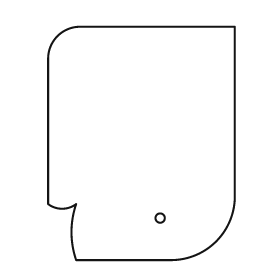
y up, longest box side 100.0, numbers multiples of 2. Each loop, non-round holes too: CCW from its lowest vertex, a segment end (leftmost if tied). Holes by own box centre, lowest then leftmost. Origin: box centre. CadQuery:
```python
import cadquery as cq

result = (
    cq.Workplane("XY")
    .moveTo(-28.0, -50.0)
    .lineTo(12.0, -50.0)
    .threePointArc((32.0, -42.0), (40.0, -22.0))
    .lineTo(40.0, 50.0)
    .lineTo(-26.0, 50.0)
    .threePointArc((-36.0, 46.0), (-40.0, 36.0))
    .lineTo(-40.0, -26.0)
    .threePointArc((-34.0, -28.0), (-28.0, -26.0))
    .threePointArc((-30.0, -38.0), (-28.0, -50.0))
    .close()
    .moveTo(8.0, -32.0)
    .circle(2.0)
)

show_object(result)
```